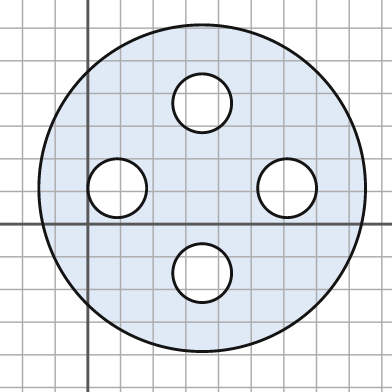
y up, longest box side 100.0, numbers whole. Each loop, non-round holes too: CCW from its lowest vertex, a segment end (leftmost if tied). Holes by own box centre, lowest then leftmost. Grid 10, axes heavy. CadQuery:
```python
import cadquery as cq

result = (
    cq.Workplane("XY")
    .moveTo(35.0, 11.0)
    .circle(50.0)
    .moveTo(35.0, -15.0)
    .circle(9.0)
    .moveTo(9.0, 11.0)
    .circle(9.0)
    .moveTo(61.0, 11.0)
    .circle(9.0)
    .moveTo(35.0, 37.0)
    .circle(9.0)
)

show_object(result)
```